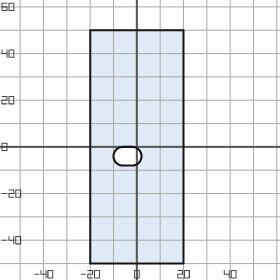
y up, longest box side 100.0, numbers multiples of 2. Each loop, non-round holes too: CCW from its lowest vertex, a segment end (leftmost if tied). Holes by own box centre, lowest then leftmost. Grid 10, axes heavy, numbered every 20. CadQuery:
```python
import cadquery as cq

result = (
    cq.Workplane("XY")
    .moveTo(-20.0, -50.0)
    .lineTo(20.0, -50.0)
    .lineTo(20.0, 50.0)
    .lineTo(-20.0, 50.0)
    .close()
    .moveTo(-6.0, -8.0)
    .lineTo(-2.0, -8.0)
    .threePointArc((2.0, -4.0), (-2.0, 0.0))
    .lineTo(-6.0, 0.0)
    .threePointArc((-10.0, -4.0), (-6.0, -8.0))
    .close()
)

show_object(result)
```